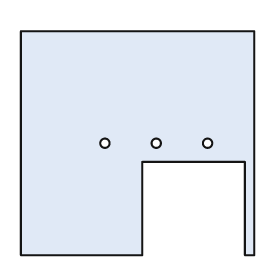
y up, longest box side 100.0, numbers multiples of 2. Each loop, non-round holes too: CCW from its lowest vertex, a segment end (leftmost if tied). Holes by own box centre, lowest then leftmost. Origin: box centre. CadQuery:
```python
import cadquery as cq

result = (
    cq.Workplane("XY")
    .moveTo(-50.0, -48.0)
    .lineTo(2.0, -48.0)
    .lineTo(2.0, -8.0)
    .lineTo(46.0, -8.0)
    .lineTo(46.0, -48.0)
    .lineTo(50.0, -48.0)
    .lineTo(50.0, 48.0)
    .lineTo(-50.0, 48.0)
    .close()
    .moveTo(-14.0, 0.0)
    .circle(2.0)
    .moveTo(8.0, 0.0)
    .circle(2.0)
    .moveTo(30.0, 0.0)
    .circle(2.0)
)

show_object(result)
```